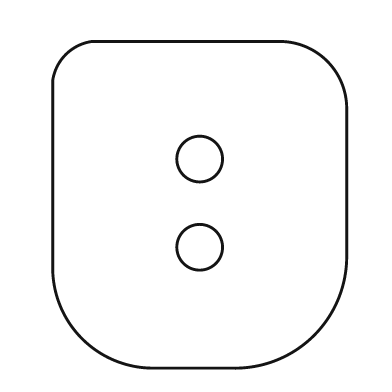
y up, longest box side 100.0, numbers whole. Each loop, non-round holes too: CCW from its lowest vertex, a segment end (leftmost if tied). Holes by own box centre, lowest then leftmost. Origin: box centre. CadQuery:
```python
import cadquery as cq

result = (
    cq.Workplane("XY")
    .moveTo(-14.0, -50.0)
    .lineTo(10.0, -50.0)
    .threePointArc((35.0, -40.0), (45.0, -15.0))
    .lineTo(45.0, 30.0)
    .threePointArc((39.0, 44.0), (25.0, 50.0))
    .lineTo(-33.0, 50.0)
    .threePointArc((-41.0, 46.0), (-45.0, 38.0))
    .lineTo(-45.0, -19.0)
    .threePointArc((-36.0, -41.0), (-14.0, -50.0))
    .close()
    .moveTo(0.0, -13.0)
    .circle(7.0)
    .moveTo(0.0, 14.0)
    .circle(7.0)
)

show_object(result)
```